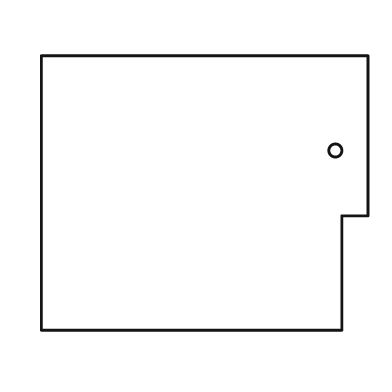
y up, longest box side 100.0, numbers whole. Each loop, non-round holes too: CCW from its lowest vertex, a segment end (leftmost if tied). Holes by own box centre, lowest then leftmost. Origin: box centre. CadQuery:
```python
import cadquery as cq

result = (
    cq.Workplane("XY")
    .moveTo(-50.0, -42.0)
    .lineTo(42.0, -42.0)
    .lineTo(42.0, -7.0)
    .lineTo(50.0, -7.0)
    .lineTo(50.0, 42.0)
    .lineTo(-50.0, 42.0)
    .close()
    .moveTo(40.0, 13.0)
    .circle(2.0)
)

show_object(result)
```